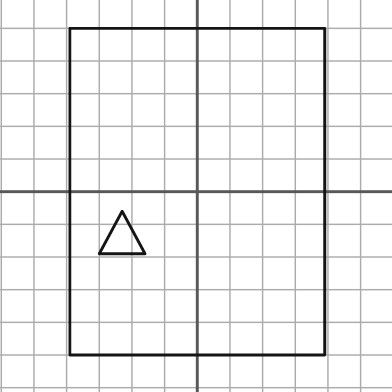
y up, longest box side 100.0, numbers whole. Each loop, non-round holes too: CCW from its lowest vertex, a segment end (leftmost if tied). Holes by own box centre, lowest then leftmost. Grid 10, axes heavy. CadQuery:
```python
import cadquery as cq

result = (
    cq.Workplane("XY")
    .moveTo(-39.0, -50.0)
    .lineTo(39.0, -50.0)
    .lineTo(39.0, 50.0)
    .lineTo(-39.0, 50.0)
    .close()
    .moveTo(-30.0, -19.0)
    .lineTo(-16.0, -19.0)
    .lineTo(-23.0, -6.0)
    .close()
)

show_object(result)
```